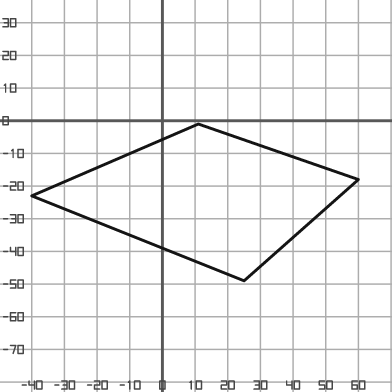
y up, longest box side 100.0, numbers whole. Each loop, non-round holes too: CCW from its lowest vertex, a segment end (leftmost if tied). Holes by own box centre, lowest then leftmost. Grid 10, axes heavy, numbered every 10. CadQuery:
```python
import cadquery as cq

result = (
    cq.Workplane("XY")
    .moveTo(25.0, -49.0)
    .lineTo(60.0, -18.0)
    .lineTo(11.0, -1.0)
    .lineTo(-40.0, -23.0)
    .close()
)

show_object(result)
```